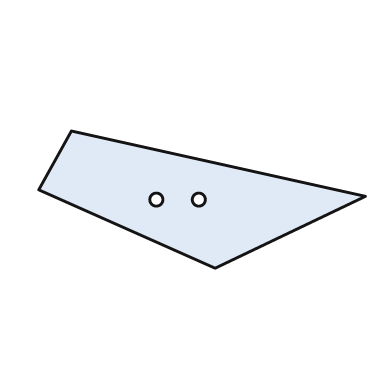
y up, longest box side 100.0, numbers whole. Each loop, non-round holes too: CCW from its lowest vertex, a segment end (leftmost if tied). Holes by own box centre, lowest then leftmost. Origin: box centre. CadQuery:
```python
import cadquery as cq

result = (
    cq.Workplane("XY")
    .moveTo(4.0, -21.0)
    .lineTo(50.0, 1.0)
    .lineTo(-40.0, 21.0)
    .lineTo(-50.0, 3.0)
    .close()
    .moveTo(-14.0, 0.0)
    .circle(2.0)
    .moveTo(-1.0, 0.0)
    .circle(2.0)
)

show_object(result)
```